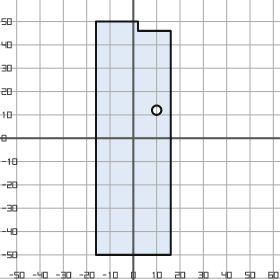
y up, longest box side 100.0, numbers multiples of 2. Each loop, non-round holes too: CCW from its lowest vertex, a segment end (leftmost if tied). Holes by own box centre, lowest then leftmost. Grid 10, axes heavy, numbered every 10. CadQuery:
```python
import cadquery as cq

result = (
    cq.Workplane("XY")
    .moveTo(-16.0, -50.0)
    .lineTo(16.0, -50.0)
    .lineTo(16.0, 46.0)
    .lineTo(2.0, 46.0)
    .lineTo(2.0, 50.0)
    .lineTo(-16.0, 50.0)
    .close()
    .moveTo(10.0, 12.0)
    .circle(2.0)
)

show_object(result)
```